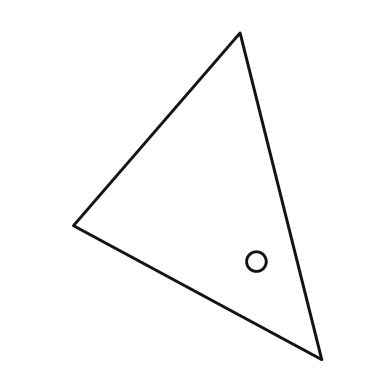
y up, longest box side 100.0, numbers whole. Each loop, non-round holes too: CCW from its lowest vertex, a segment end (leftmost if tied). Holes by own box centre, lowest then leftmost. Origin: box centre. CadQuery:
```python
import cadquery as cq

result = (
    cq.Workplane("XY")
    .moveTo(38.0, -50.0)
    .lineTo(13.0, 50.0)
    .lineTo(-38.0, -9.0)
    .close()
    .moveTo(18.0, -20.0)
    .circle(3.0)
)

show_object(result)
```